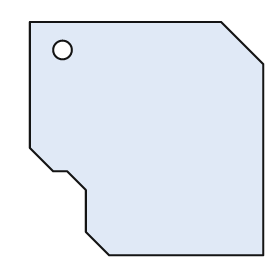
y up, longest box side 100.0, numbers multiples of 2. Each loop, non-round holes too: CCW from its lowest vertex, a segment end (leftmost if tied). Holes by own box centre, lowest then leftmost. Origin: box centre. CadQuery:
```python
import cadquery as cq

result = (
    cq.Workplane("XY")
    .moveTo(-16.0, -50.0)
    .lineTo(50.0, -50.0)
    .lineTo(50.0, 32.0)
    .lineTo(32.0, 50.0)
    .lineTo(-50.0, 50.0)
    .lineTo(-50.0, -4.0)
    .lineTo(-40.0, -14.0)
    .lineTo(-34.0, -14.0)
    .lineTo(-26.0, -22.0)
    .lineTo(-26.0, -40.0)
    .close()
    .moveTo(-36.0, 38.0)
    .circle(4.0)
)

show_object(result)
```